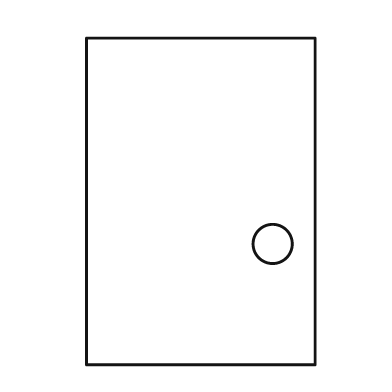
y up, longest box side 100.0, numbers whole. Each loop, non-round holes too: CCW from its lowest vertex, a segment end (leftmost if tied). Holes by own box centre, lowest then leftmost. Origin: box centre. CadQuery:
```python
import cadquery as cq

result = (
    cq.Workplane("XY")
    .moveTo(-35.0, -50.0)
    .lineTo(35.0, -50.0)
    .lineTo(35.0, 50.0)
    .lineTo(-35.0, 50.0)
    .close()
    .moveTo(22.0, -13.0)
    .circle(6.0)
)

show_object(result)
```